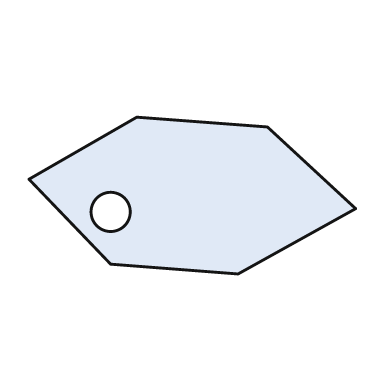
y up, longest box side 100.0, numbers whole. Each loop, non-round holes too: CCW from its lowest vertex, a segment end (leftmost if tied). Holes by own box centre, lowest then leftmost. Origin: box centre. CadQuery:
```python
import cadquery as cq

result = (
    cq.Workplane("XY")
    .moveTo(14.0, -24.0)
    .lineTo(50.0, -4.0)
    .lineTo(23.0, 21.0)
    .lineTo(-17.0, 24.0)
    .lineTo(-50.0, 5.0)
    .lineTo(-25.0, -21.0)
    .close()
    .moveTo(-25.0, -5.0)
    .circle(6.0)
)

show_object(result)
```